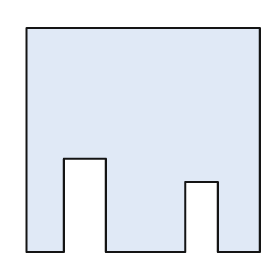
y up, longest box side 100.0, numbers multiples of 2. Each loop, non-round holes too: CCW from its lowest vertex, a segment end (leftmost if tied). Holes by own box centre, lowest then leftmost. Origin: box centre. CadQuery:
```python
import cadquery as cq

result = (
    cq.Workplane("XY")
    .moveTo(-50.0, -48.0)
    .lineTo(-34.0, -48.0)
    .lineTo(-34.0, -8.0)
    .lineTo(-16.0, -8.0)
    .lineTo(-16.0, -48.0)
    .lineTo(18.0, -48.0)
    .lineTo(18.0, -18.0)
    .lineTo(32.0, -18.0)
    .lineTo(32.0, -48.0)
    .lineTo(50.0, -48.0)
    .lineTo(50.0, 48.0)
    .lineTo(-50.0, 48.0)
    .close()
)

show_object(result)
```